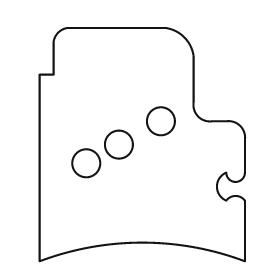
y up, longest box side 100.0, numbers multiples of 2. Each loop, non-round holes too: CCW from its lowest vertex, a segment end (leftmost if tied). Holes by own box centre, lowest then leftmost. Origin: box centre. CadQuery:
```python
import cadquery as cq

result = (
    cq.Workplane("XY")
    .moveTo(-44.0, -50.0)
    .threePointArc((0.0, -42.0), (44.0, -50.0))
    .lineTo(44.0, -24.0)
    .threePointArc((40.0, -22.0), (36.0, -24.0))
    .threePointArc((32.0, -18.0), (36.0, -12.0))
    .threePointArc((40.0, -16.0), (44.0, -12.0))
    .lineTo(44.0, 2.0)
    .threePointArc((42.0, 8.0), (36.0, 10.0))
    .lineTo(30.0, 10.0)
    .threePointArc((24.0, 12.0), (22.0, 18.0))
    .lineTo(22.0, 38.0)
    .threePointArc((18.0, 46.0), (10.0, 50.0))
    .lineTo(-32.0, 50.0)
    .threePointArc((-36.0, 48.0), (-38.0, 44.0))
    .lineTo(-38.0, 30.0)
    .lineTo(-44.0, 30.0)
    .close()
    .moveTo(-24.0, -8.0)
    .circle(6.0)
    .moveTo(-10.0, 0.0)
    .circle(6.0)
    .moveTo(8.0, 10.0)
    .circle(6.0)
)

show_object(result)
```